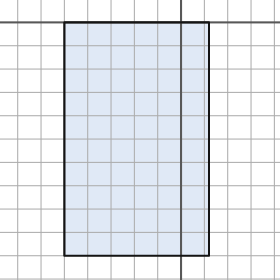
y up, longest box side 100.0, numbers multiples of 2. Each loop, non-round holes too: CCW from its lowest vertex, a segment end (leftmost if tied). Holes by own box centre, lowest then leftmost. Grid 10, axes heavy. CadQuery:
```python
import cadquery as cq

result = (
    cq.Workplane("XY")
    .moveTo(-50.0, -100.0)
    .lineTo(12.0, -100.0)
    .lineTo(12.0, 0.0)
    .lineTo(-50.0, 0.0)
    .close()
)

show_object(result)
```